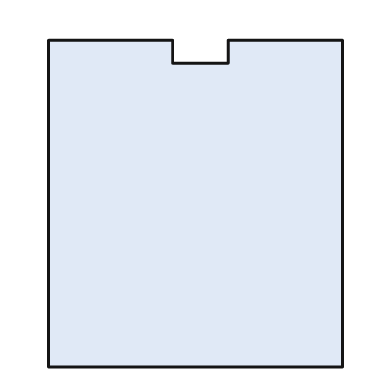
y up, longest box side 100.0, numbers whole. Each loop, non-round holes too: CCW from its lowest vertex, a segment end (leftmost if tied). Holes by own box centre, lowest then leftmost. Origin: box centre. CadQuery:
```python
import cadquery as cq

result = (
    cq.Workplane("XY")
    .moveTo(-45.0, -50.0)
    .lineTo(45.0, -50.0)
    .lineTo(45.0, 50.0)
    .lineTo(10.0, 50.0)
    .lineTo(10.0, 43.0)
    .lineTo(-7.0, 43.0)
    .lineTo(-7.0, 50.0)
    .lineTo(-45.0, 50.0)
    .close()
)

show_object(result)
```